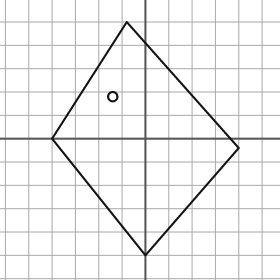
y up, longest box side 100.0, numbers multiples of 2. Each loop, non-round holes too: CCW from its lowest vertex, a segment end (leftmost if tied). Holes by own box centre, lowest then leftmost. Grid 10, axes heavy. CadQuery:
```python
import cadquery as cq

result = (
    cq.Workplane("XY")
    .moveTo(0.0, -50.0)
    .lineTo(40.0, -4.0)
    .lineTo(-8.0, 50.0)
    .lineTo(-40.0, 0.0)
    .close()
    .moveTo(-14.0, 18.0)
    .circle(2.0)
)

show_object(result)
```